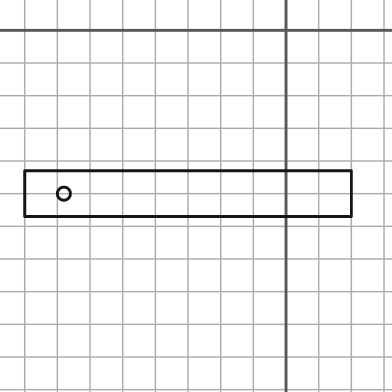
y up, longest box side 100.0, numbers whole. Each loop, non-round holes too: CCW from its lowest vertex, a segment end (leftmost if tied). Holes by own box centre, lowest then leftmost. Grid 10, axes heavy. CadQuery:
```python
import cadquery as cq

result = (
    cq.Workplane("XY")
    .moveTo(-80.0, -57.0)
    .lineTo(20.0, -57.0)
    .lineTo(20.0, -43.0)
    .lineTo(-80.0, -43.0)
    .close()
    .moveTo(-68.0, -50.0)
    .circle(2.0)
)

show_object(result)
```